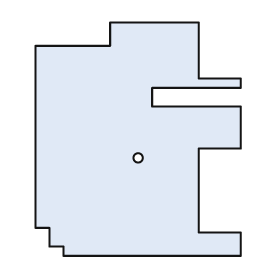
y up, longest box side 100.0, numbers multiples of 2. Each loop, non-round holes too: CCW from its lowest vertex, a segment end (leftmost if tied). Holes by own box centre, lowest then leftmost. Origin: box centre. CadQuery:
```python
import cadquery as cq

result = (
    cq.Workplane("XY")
    .moveTo(-32.0, -50.0)
    .lineTo(44.0, -50.0)
    .lineTo(44.0, -40.0)
    .lineTo(26.0, -40.0)
    .lineTo(26.0, -4.0)
    .lineTo(44.0, -4.0)
    .lineTo(44.0, 14.0)
    .lineTo(6.0, 14.0)
    .lineTo(6.0, 22.0)
    .lineTo(44.0, 22.0)
    .lineTo(44.0, 26.0)
    .lineTo(26.0, 26.0)
    .lineTo(26.0, 50.0)
    .lineTo(-12.0, 50.0)
    .lineTo(-12.0, 40.0)
    .lineTo(-44.0, 40.0)
    .lineTo(-44.0, -38.0)
    .lineTo(-38.0, -38.0)
    .lineTo(-38.0, -46.0)
    .lineTo(-32.0, -46.0)
    .close()
    .moveTo(0.0, -8.0)
    .circle(2.0)
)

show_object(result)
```